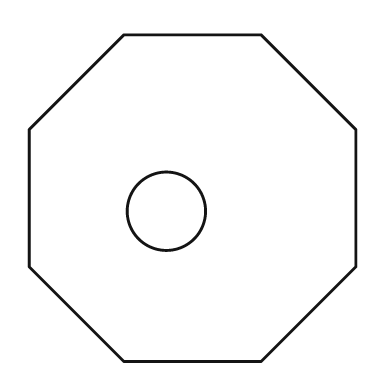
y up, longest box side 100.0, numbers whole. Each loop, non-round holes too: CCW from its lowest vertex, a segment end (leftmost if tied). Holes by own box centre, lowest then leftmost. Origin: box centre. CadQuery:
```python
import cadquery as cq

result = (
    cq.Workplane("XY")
    .moveTo(-21.0, -50.0)
    .lineTo(21.0, -50.0)
    .lineTo(50.0, -21.0)
    .lineTo(50.0, 21.0)
    .lineTo(21.0, 50.0)
    .lineTo(-21.0, 50.0)
    .lineTo(-50.0, 21.0)
    .lineTo(-50.0, -21.0)
    .close()
    .moveTo(-8.0, -4.0)
    .circle(12.0)
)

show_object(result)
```